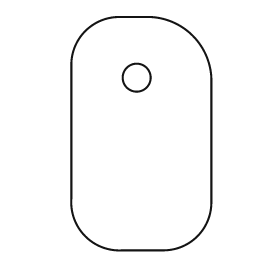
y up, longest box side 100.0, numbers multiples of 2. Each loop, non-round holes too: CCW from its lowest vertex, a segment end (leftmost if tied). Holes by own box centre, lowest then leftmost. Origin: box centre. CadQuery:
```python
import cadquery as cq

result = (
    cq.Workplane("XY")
    .moveTo(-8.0, -50.0)
    .lineTo(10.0, -50.0)
    .threePointArc((24.0, -44.0), (30.0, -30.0))
    .lineTo(30.0, 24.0)
    .threePointArc((22.0, 42.0), (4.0, 50.0))
    .lineTo(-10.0, 50.0)
    .threePointArc((-24.0, 44.0), (-30.0, 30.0))
    .lineTo(-30.0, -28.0)
    .threePointArc((-24.0, -44.0), (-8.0, -50.0))
    .close()
    .moveTo(-2.0, 24.0)
    .circle(6.0)
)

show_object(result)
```